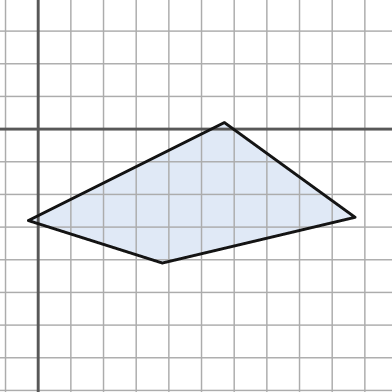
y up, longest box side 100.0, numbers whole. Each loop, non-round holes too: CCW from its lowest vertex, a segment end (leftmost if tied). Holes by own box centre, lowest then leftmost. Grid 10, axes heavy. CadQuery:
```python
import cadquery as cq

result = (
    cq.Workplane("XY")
    .moveTo(38.0, -41.0)
    .lineTo(97.0, -27.0)
    .lineTo(57.0, 2.0)
    .lineTo(-3.0, -28.0)
    .close()
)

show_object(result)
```